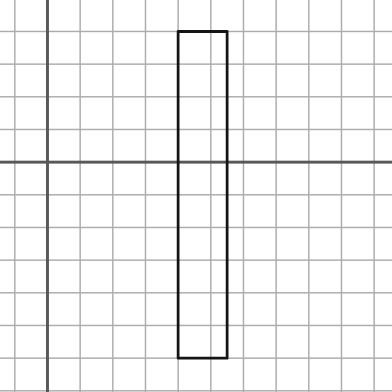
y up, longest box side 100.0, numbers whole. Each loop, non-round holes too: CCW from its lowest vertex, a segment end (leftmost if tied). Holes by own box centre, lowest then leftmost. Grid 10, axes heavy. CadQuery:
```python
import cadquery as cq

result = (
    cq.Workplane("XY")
    .moveTo(40.0, -60.0)
    .lineTo(55.0, -60.0)
    .lineTo(55.0, 40.0)
    .lineTo(40.0, 40.0)
    .close()
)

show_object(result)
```